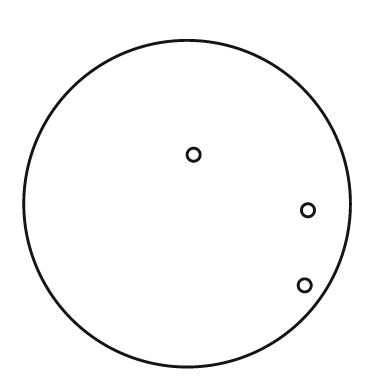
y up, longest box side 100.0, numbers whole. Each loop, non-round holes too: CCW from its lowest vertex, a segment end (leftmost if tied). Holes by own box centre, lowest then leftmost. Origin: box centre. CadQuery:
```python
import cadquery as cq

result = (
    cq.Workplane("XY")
    .moveTo(0.0, 0.0)
    .circle(50.0)
    .moveTo(36.0, -25.0)
    .circle(2.0)
    .moveTo(37.0, -2.0)
    .circle(2.0)
    .moveTo(2.0, 15.0)
    .circle(2.0)
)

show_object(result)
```